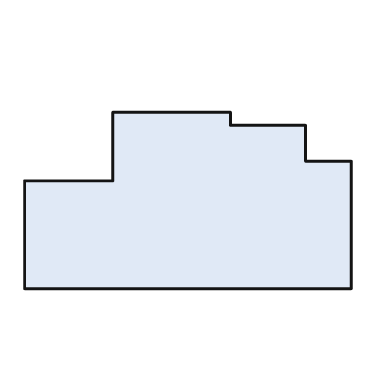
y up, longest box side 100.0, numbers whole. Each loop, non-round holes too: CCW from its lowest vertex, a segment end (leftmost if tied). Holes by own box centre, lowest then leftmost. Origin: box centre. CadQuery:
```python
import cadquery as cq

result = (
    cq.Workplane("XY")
    .moveTo(-50.0, -27.0)
    .lineTo(50.0, -27.0)
    .lineTo(50.0, 12.0)
    .lineTo(36.0, 12.0)
    .lineTo(36.0, 23.0)
    .lineTo(13.0, 23.0)
    .lineTo(13.0, 27.0)
    .lineTo(-23.0, 27.0)
    .lineTo(-23.0, 6.0)
    .lineTo(-50.0, 6.0)
    .close()
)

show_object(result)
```